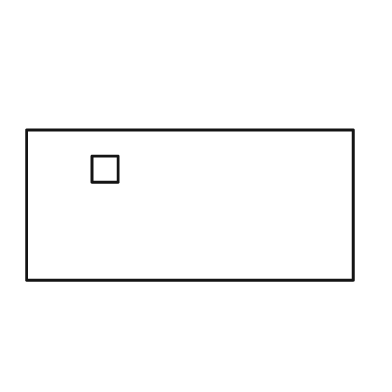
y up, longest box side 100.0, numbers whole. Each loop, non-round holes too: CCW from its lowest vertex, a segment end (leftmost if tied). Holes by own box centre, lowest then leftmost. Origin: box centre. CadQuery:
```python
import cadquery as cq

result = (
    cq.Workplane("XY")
    .moveTo(-50.0, -23.0)
    .lineTo(50.0, -23.0)
    .lineTo(50.0, 23.0)
    .lineTo(-50.0, 23.0)
    .close()
    .moveTo(-30.0, 7.0)
    .lineTo(-22.0, 7.0)
    .lineTo(-22.0, 15.0)
    .lineTo(-30.0, 15.0)
    .close()
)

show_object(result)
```